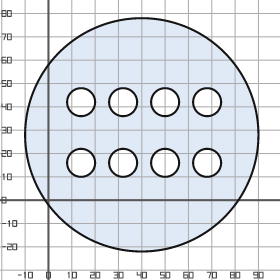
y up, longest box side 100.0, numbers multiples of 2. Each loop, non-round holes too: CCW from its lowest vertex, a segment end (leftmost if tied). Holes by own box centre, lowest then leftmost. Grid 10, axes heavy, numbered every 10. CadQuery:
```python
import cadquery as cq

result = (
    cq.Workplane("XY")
    .moveTo(40.0, 28.0)
    .circle(50.0)
    .moveTo(14.0, 16.0)
    .circle(6.0)
    .moveTo(32.0, 16.0)
    .circle(6.0)
    .moveTo(50.0, 16.0)
    .circle(6.0)
    .moveTo(68.0, 16.0)
    .circle(6.0)
    .moveTo(14.0, 42.0)
    .circle(6.0)
    .moveTo(32.0, 42.0)
    .circle(6.0)
    .moveTo(50.0, 42.0)
    .circle(6.0)
    .moveTo(68.0, 42.0)
    .circle(6.0)
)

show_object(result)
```